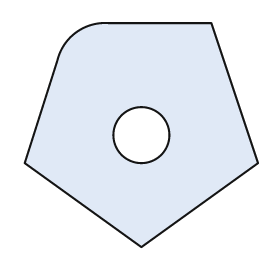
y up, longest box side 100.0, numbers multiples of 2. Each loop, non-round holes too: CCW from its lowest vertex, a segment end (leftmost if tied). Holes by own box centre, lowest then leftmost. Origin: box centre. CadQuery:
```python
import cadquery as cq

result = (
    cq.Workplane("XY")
    .moveTo(0.0, -48.0)
    .lineTo(50.0, -12.0)
    .lineTo(30.0, 48.0)
    .lineTo(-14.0, 48.0)
    .threePointArc((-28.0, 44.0), (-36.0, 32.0))
    .lineTo(-50.0, -12.0)
    .close()
    .moveTo(0.0, 0.0)
    .circle(12.0)
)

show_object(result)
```